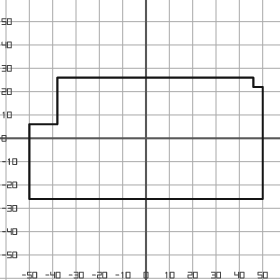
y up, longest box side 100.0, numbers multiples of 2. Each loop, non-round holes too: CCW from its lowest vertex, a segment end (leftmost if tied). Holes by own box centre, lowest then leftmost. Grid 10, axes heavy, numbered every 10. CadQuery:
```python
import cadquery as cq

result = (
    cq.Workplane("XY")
    .moveTo(-50.0, -26.0)
    .lineTo(50.0, -26.0)
    .lineTo(50.0, 22.0)
    .lineTo(46.0, 22.0)
    .lineTo(46.0, 26.0)
    .lineTo(-38.0, 26.0)
    .lineTo(-38.0, 6.0)
    .lineTo(-50.0, 6.0)
    .close()
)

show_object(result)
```